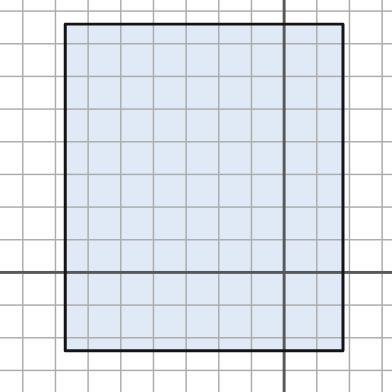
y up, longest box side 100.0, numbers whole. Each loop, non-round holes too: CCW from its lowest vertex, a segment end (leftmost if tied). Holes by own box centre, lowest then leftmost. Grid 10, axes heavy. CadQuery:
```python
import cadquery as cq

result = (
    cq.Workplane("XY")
    .moveTo(-67.0, -24.0)
    .lineTo(18.0, -24.0)
    .lineTo(18.0, 76.0)
    .lineTo(-67.0, 76.0)
    .close()
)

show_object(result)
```